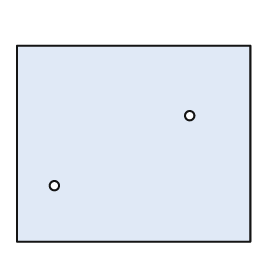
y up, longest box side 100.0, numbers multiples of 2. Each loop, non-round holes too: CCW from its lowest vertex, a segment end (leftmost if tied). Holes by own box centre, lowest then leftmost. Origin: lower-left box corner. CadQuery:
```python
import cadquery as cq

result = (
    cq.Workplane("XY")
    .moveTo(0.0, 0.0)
    .lineTo(100.0, 0.0)
    .lineTo(100.0, 84.0)
    .lineTo(0.0, 84.0)
    .close()
    .moveTo(16.0, 24.0)
    .circle(2.0)
    .moveTo(74.0, 54.0)
    .circle(2.0)
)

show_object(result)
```